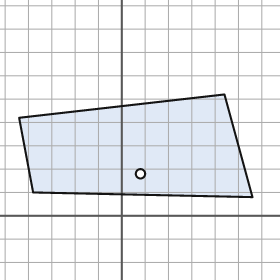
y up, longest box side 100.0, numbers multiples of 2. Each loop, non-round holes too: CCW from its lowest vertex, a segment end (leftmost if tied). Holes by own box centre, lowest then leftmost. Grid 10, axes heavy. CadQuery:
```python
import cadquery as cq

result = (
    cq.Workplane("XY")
    .moveTo(56.0, 8.0)
    .lineTo(44.0, 52.0)
    .lineTo(-44.0, 42.0)
    .lineTo(-38.0, 10.0)
    .close()
    .moveTo(8.0, 18.0)
    .circle(2.0)
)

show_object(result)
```